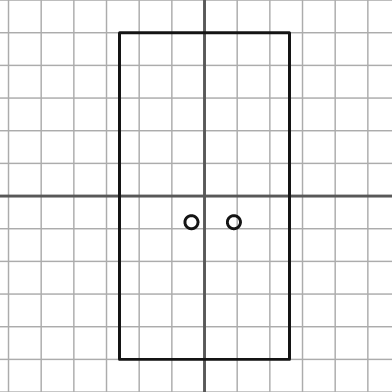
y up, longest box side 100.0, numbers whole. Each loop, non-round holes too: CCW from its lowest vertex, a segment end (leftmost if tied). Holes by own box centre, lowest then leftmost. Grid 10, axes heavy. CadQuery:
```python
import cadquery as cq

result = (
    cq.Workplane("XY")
    .moveTo(-26.0, -50.0)
    .lineTo(26.0, -50.0)
    .lineTo(26.0, 50.0)
    .lineTo(-26.0, 50.0)
    .close()
    .moveTo(-4.0, -8.0)
    .circle(2.0)
    .moveTo(9.0, -8.0)
    .circle(2.0)
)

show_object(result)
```